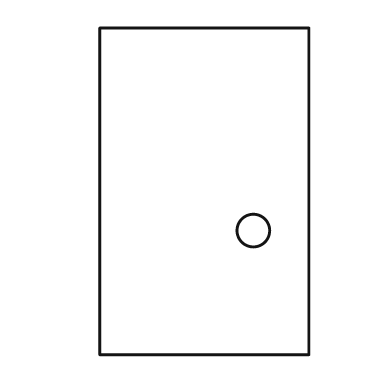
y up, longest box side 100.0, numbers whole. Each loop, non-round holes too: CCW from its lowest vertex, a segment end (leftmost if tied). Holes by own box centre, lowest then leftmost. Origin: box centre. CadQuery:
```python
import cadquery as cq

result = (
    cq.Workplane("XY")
    .moveTo(-32.0, -50.0)
    .lineTo(32.0, -50.0)
    .lineTo(32.0, 50.0)
    .lineTo(-32.0, 50.0)
    .close()
    .moveTo(15.0, -12.0)
    .circle(5.0)
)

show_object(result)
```